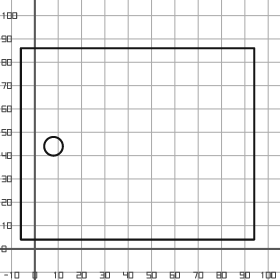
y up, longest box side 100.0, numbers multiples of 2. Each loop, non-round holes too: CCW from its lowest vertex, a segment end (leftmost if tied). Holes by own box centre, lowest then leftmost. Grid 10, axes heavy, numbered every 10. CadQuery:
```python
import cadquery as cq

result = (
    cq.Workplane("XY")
    .moveTo(-6.0, 4.0)
    .lineTo(94.0, 4.0)
    .lineTo(94.0, 86.0)
    .lineTo(-6.0, 86.0)
    .close()
    .moveTo(8.0, 44.0)
    .circle(4.0)
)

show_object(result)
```